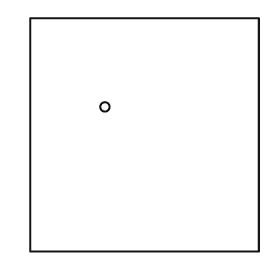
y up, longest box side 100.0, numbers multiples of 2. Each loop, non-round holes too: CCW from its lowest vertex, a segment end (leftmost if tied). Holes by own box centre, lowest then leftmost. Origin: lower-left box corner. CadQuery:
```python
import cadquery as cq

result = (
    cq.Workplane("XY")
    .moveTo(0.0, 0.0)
    .lineTo(98.0, 0.0)
    .lineTo(98.0, 100.0)
    .lineTo(0.0, 100.0)
    .close()
    .moveTo(32.0, 62.0)
    .circle(2.0)
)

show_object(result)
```